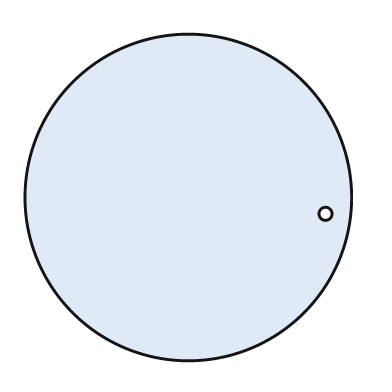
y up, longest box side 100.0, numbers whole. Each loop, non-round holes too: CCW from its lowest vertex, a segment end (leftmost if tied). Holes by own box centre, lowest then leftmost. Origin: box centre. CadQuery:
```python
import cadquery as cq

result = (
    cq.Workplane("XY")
    .moveTo(0.0, 0.0)
    .circle(50.0)
    .moveTo(42.0, -5.0)
    .circle(2.0)
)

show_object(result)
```